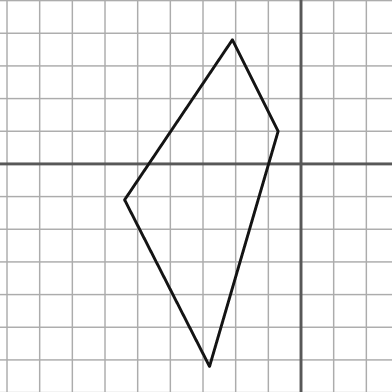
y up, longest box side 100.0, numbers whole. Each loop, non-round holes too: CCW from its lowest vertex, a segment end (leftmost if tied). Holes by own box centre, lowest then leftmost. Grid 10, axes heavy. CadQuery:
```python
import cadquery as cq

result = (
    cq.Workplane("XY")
    .moveTo(-28.0, -62.0)
    .lineTo(-7.0, 10.0)
    .lineTo(-21.0, 38.0)
    .lineTo(-54.0, -11.0)
    .close()
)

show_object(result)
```